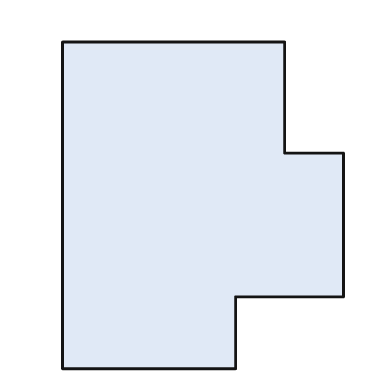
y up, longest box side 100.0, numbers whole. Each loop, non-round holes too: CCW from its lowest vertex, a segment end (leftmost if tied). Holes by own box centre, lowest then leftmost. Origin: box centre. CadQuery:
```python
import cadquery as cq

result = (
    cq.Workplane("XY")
    .moveTo(-43.0, -50.0)
    .lineTo(10.0, -50.0)
    .lineTo(10.0, -28.0)
    .lineTo(43.0, -28.0)
    .lineTo(43.0, 16.0)
    .lineTo(25.0, 16.0)
    .lineTo(25.0, 50.0)
    .lineTo(-43.0, 50.0)
    .close()
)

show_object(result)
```